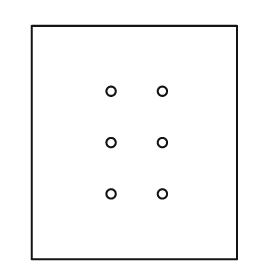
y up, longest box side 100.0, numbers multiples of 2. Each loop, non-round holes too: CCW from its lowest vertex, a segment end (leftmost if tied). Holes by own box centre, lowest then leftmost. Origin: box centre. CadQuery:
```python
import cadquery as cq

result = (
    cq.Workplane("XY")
    .moveTo(-44.0, -50.0)
    .lineTo(44.0, -50.0)
    .lineTo(44.0, 50.0)
    .lineTo(-44.0, 50.0)
    .close()
    .moveTo(-10.0, -22.0)
    .circle(2.0)
    .moveTo(12.0, -22.0)
    .circle(2.0)
    .moveTo(-10.0, 0.0)
    .circle(2.0)
    .moveTo(12.0, 0.0)
    .circle(2.0)
    .moveTo(-10.0, 22.0)
    .circle(2.0)
    .moveTo(12.0, 22.0)
    .circle(2.0)
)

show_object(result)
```